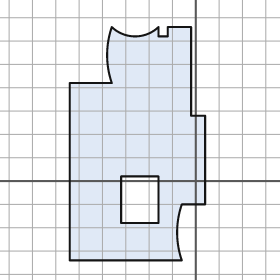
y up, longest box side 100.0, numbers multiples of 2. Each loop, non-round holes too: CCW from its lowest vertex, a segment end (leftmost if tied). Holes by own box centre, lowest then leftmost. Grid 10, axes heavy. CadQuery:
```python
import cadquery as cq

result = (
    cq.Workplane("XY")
    .moveTo(-54.0, -34.0)
    .lineTo(-6.0, -34.0)
    .threePointArc((-8.0, -22.0), (-6.0, -10.0))
    .lineTo(4.0, -10.0)
    .lineTo(4.0, 28.0)
    .lineTo(-2.0, 28.0)
    .lineTo(-2.0, 66.0)
    .lineTo(-12.0, 66.0)
    .lineTo(-12.0, 62.0)
    .lineTo(-16.0, 62.0)
    .lineTo(-16.0, 66.0)
    .threePointArc((-26.0, 62.0), (-36.0, 66.0))
    .threePointArc((-38.0, 54.0), (-36.0, 42.0))
    .lineTo(-54.0, 42.0)
    .close()
    .moveTo(-32.0, -18.0)
    .lineTo(-16.0, -18.0)
    .lineTo(-16.0, 2.0)
    .lineTo(-32.0, 2.0)
    .close()
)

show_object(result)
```